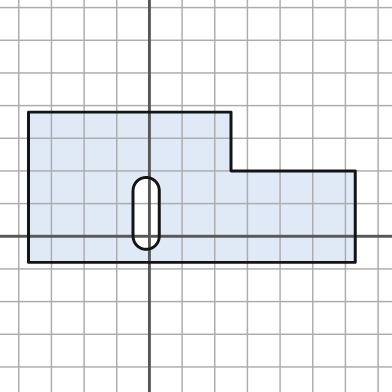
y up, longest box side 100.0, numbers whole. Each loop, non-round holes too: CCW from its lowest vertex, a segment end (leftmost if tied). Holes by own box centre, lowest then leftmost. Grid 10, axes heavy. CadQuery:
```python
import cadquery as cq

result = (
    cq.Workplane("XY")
    .moveTo(-37.0, -8.0)
    .lineTo(63.0, -8.0)
    .lineTo(63.0, 20.0)
    .lineTo(25.0, 20.0)
    .lineTo(25.0, 38.0)
    .lineTo(-37.0, 38.0)
    .close()
    .moveTo(-5.0, 0.0)
    .threePointArc((-1.0, -4.0), (3.0, 0.0))
    .lineTo(3.0, 14.0)
    .threePointArc((-1.0, 18.0), (-5.0, 14.0))
    .close()
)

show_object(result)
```